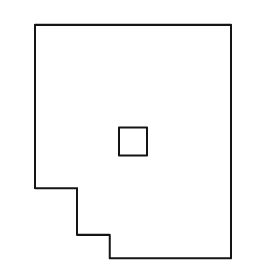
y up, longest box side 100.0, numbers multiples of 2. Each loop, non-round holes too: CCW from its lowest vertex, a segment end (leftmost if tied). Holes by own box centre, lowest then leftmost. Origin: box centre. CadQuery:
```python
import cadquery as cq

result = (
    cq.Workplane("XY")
    .moveTo(-10.0, -50.0)
    .lineTo(42.0, -50.0)
    .lineTo(42.0, 50.0)
    .lineTo(-42.0, 50.0)
    .lineTo(-42.0, -20.0)
    .lineTo(-24.0, -20.0)
    .lineTo(-24.0, -40.0)
    .lineTo(-10.0, -40.0)
    .close()
    .moveTo(-6.0, -6.0)
    .lineTo(6.0, -6.0)
    .lineTo(6.0, 6.0)
    .lineTo(-6.0, 6.0)
    .close()
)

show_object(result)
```